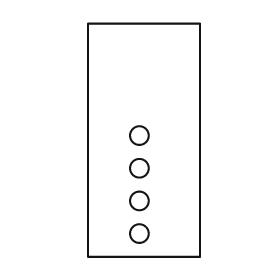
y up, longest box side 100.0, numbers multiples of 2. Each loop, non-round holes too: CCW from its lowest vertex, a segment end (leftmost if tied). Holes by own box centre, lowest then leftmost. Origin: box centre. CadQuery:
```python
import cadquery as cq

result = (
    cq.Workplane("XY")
    .moveTo(-24.0, -50.0)
    .lineTo(24.0, -50.0)
    .lineTo(24.0, 50.0)
    .lineTo(-24.0, 50.0)
    .close()
    .moveTo(-2.0, -40.0)
    .circle(4.0)
    .moveTo(-2.0, -26.0)
    .circle(4.0)
    .moveTo(-2.0, -12.0)
    .circle(4.0)
    .moveTo(-2.0, 2.0)
    .circle(4.0)
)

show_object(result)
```